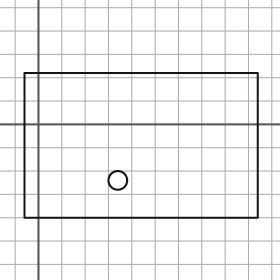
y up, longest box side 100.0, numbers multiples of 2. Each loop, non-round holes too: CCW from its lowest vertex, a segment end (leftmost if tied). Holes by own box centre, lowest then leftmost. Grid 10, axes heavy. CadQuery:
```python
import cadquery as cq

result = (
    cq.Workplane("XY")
    .moveTo(-6.0, -40.0)
    .lineTo(94.0, -40.0)
    .lineTo(94.0, 22.0)
    .lineTo(-6.0, 22.0)
    .close()
    .moveTo(34.0, -24.0)
    .circle(4.0)
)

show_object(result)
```